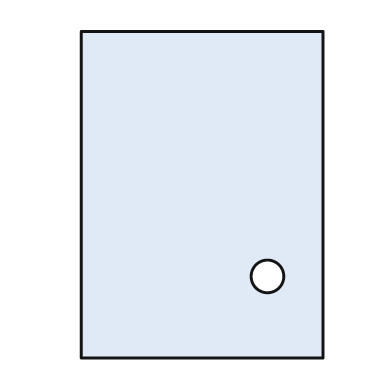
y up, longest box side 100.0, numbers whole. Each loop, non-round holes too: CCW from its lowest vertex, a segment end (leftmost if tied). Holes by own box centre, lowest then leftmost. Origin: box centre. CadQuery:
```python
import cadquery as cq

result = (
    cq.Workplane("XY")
    .moveTo(-37.0, -50.0)
    .lineTo(37.0, -50.0)
    .lineTo(37.0, 50.0)
    .lineTo(-37.0, 50.0)
    .close()
    .moveTo(20.0, -25.0)
    .circle(5.0)
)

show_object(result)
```